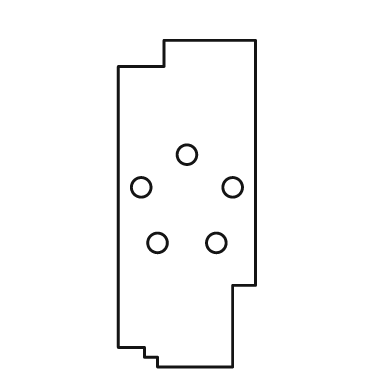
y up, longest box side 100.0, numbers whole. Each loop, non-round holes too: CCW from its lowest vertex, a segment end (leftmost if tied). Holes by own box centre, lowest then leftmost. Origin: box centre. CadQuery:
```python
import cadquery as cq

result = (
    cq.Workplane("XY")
    .moveTo(-9.0, -50.0)
    .lineTo(14.0, -50.0)
    .lineTo(14.0, -25.0)
    .lineTo(21.0, -25.0)
    .lineTo(21.0, 50.0)
    .lineTo(-7.0, 50.0)
    .lineTo(-7.0, 42.0)
    .lineTo(-21.0, 42.0)
    .lineTo(-21.0, -44.0)
    .lineTo(-13.0, -44.0)
    .lineTo(-13.0, -47.0)
    .lineTo(-9.0, -47.0)
    .close()
    .moveTo(-9.0, -12.0)
    .circle(3.0)
    .moveTo(9.0, -12.0)
    .circle(3.0)
    .moveTo(-14.0, 5.0)
    .circle(3.0)
    .moveTo(14.0, 5.0)
    .circle(3.0)
    .moveTo(0.0, 15.0)
    .circle(3.0)
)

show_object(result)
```